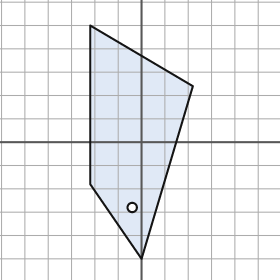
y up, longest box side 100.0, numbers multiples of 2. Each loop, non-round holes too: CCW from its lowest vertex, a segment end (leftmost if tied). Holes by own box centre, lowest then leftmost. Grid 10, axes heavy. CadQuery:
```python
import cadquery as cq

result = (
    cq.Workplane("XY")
    .moveTo(0.0, -50.0)
    .lineTo(22.0, 24.0)
    .lineTo(-22.0, 50.0)
    .lineTo(-22.0, -18.0)
    .close()
    .moveTo(-4.0, -28.0)
    .circle(2.0)
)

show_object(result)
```